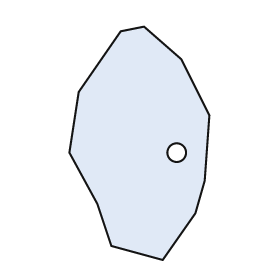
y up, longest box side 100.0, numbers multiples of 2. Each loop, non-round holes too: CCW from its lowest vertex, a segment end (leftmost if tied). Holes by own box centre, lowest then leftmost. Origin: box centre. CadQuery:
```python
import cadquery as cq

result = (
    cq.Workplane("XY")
    .moveTo(10.0, -50.0)
    .lineTo(24.0, -30.0)
    .lineTo(28.0, -16.0)
    .lineTo(30.0, 12.0)
    .lineTo(18.0, 36.0)
    .lineTo(2.0, 50.0)
    .lineTo(-8.0, 48.0)
    .lineTo(-26.0, 22.0)
    .lineTo(-30.0, -4.0)
    .lineTo(-18.0, -26.0)
    .lineTo(-12.0, -44.0)
    .close()
    .moveTo(16.0, -4.0)
    .circle(4.0)
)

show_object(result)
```